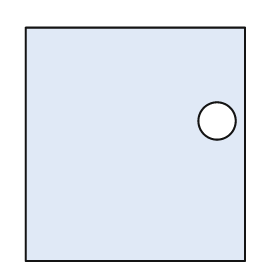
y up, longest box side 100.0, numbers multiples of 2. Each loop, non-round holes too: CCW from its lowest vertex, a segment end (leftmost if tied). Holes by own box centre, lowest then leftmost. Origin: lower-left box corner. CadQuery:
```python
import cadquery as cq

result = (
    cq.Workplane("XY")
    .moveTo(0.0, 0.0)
    .lineTo(94.0, 0.0)
    .lineTo(94.0, 100.0)
    .lineTo(0.0, 100.0)
    .close()
    .moveTo(82.0, 60.0)
    .circle(8.0)
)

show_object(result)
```